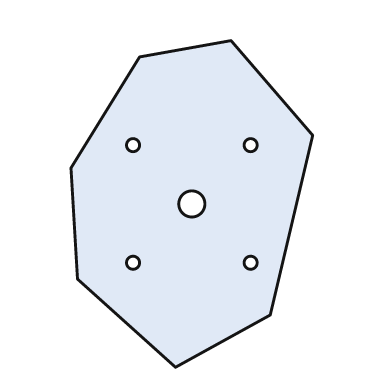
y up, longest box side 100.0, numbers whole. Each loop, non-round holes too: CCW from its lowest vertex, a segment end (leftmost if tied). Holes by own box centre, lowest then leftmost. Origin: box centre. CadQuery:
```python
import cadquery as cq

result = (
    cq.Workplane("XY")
    .moveTo(-5.0, -50.0)
    .lineTo(24.0, -34.0)
    .lineTo(37.0, 21.0)
    .lineTo(12.0, 50.0)
    .lineTo(-16.0, 45.0)
    .lineTo(-37.0, 11.0)
    .lineTo(-35.0, -23.0)
    .close()
    .moveTo(-18.0, -18.0)
    .circle(2.0)
    .moveTo(18.0, -18.0)
    .circle(2.0)
    .moveTo(0.0, 0.0)
    .circle(4.0)
    .moveTo(-18.0, 18.0)
    .circle(2.0)
    .moveTo(18.0, 18.0)
    .circle(2.0)
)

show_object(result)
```